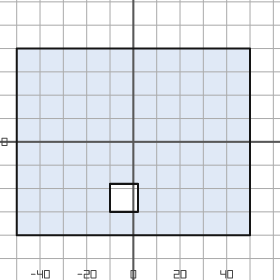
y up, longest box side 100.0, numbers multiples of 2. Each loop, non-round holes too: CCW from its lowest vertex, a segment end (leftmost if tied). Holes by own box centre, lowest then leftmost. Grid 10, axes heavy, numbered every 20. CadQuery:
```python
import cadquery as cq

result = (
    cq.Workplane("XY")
    .moveTo(-50.0, -40.0)
    .lineTo(50.0, -40.0)
    .lineTo(50.0, 40.0)
    .lineTo(-50.0, 40.0)
    .close()
    .moveTo(-10.0, -30.0)
    .lineTo(2.0, -30.0)
    .lineTo(2.0, -18.0)
    .lineTo(-10.0, -18.0)
    .close()
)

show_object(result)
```